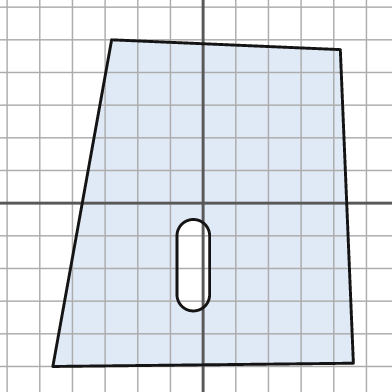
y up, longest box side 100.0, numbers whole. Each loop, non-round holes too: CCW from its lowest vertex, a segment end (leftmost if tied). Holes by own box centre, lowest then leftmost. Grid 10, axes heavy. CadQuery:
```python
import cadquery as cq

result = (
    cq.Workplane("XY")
    .moveTo(-46.0, -50.0)
    .lineTo(46.0, -49.0)
    .lineTo(42.0, 47.0)
    .lineTo(-28.0, 50.0)
    .close()
    .moveTo(-8.0, -28.0)
    .threePointArc((-3.0, -33.0), (2.0, -28.0))
    .lineTo(2.0, -10.0)
    .threePointArc((-3.0, -5.0), (-8.0, -10.0))
    .close()
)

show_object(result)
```